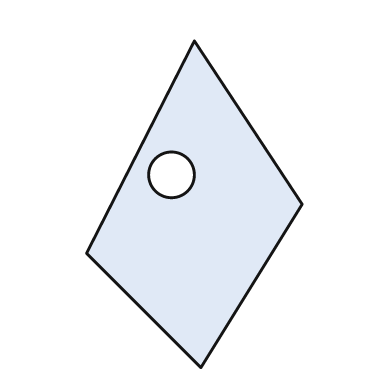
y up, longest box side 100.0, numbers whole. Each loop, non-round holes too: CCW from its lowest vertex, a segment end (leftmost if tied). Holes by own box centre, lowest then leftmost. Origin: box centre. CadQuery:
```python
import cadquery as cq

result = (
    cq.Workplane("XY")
    .moveTo(2.0, -50.0)
    .lineTo(33.0, 0.0)
    .lineTo(0.0, 50.0)
    .lineTo(-33.0, -15.0)
    .close()
    .moveTo(-7.0, 9.0)
    .circle(7.0)
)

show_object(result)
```